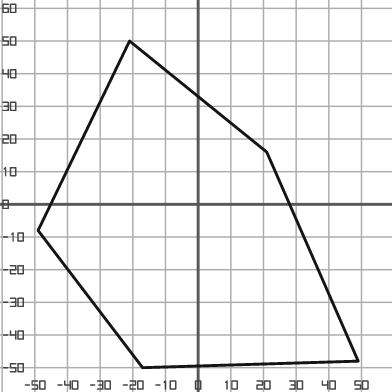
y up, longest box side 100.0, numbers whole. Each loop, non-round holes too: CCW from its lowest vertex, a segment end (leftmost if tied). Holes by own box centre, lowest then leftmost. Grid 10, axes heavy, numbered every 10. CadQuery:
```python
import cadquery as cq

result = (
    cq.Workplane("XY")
    .moveTo(-17.0, -50.0)
    .lineTo(49.0, -48.0)
    .lineTo(21.0, 16.0)
    .lineTo(-21.0, 50.0)
    .lineTo(-49.0, -8.0)
    .close()
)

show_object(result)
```